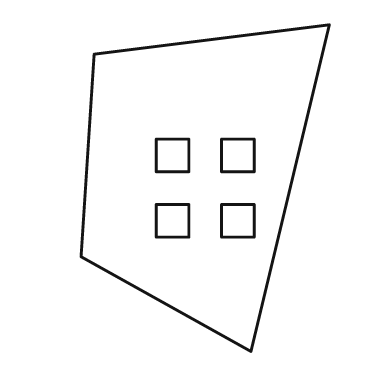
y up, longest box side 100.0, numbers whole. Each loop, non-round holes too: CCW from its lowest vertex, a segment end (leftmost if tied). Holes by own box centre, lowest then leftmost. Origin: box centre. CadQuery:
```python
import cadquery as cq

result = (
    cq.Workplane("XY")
    .moveTo(14.0, -50.0)
    .lineTo(38.0, 50.0)
    .lineTo(-34.0, 41.0)
    .lineTo(-38.0, -21.0)
    .close()
    .moveTo(-15.0, -15.0)
    .lineTo(-5.0, -15.0)
    .lineTo(-5.0, -5.0)
    .lineTo(-15.0, -5.0)
    .close()
    .moveTo(5.0, -15.0)
    .lineTo(15.0, -15.0)
    .lineTo(15.0, -5.0)
    .lineTo(5.0, -5.0)
    .close()
    .moveTo(-15.0, 5.0)
    .lineTo(-5.0, 5.0)
    .lineTo(-5.0, 15.0)
    .lineTo(-15.0, 15.0)
    .close()
    .moveTo(5.0, 5.0)
    .lineTo(15.0, 5.0)
    .lineTo(15.0, 15.0)
    .lineTo(5.0, 15.0)
    .close()
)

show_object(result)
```